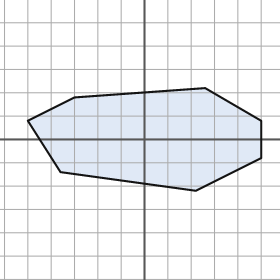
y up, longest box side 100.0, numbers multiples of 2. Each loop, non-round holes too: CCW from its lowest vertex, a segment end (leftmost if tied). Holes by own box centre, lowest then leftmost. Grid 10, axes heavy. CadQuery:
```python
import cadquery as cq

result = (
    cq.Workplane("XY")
    .moveTo(22.0, -22.0)
    .lineTo(50.0, -8.0)
    .lineTo(50.0, 8.0)
    .lineTo(26.0, 22.0)
    .lineTo(-30.0, 18.0)
    .lineTo(-50.0, 8.0)
    .lineTo(-36.0, -14.0)
    .close()
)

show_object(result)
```